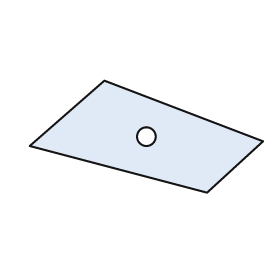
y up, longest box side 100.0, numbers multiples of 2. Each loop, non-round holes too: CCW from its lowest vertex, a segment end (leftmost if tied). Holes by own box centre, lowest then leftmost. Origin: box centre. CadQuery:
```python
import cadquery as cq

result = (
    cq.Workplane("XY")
    .moveTo(26.0, -24.0)
    .lineTo(50.0, -2.0)
    .lineTo(-18.0, 24.0)
    .lineTo(-50.0, -4.0)
    .close()
    .moveTo(0.0, 0.0)
    .circle(4.0)
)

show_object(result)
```